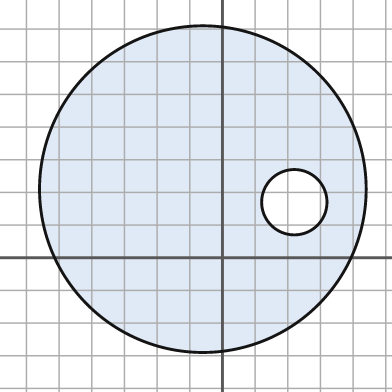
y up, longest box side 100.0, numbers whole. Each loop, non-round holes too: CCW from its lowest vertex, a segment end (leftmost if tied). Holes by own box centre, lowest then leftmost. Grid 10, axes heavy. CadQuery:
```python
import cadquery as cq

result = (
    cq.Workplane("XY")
    .moveTo(-6.0, 21.0)
    .circle(50.0)
    .moveTo(22.0, 17.0)
    .circle(10.0)
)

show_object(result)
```